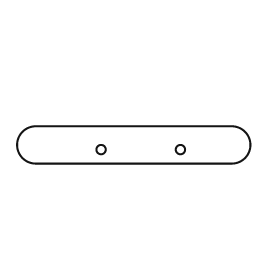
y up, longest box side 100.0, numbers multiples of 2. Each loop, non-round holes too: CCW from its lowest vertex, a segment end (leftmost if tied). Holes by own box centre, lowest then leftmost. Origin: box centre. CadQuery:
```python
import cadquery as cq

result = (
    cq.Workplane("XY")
    .moveTo(-42.0, -8.0)
    .lineTo(42.0, -8.0)
    .threePointArc((50.0, 0.0), (42.0, 8.0))
    .lineTo(-42.0, 8.0)
    .threePointArc((-50.0, 0.0), (-42.0, -8.0))
    .close()
    .moveTo(-14.0, -2.0)
    .circle(2.0)
    .moveTo(20.0, -2.0)
    .circle(2.0)
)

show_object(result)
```